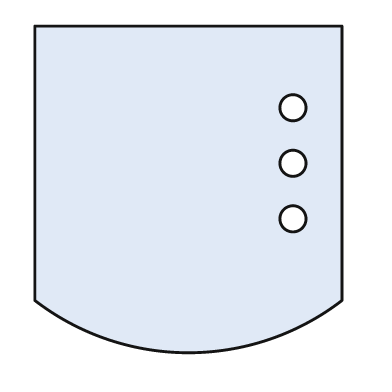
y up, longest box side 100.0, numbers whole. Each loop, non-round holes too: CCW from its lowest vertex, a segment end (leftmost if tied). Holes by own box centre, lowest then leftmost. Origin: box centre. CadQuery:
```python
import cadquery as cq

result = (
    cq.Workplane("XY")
    .moveTo(-47.0, -34.0)
    .threePointArc((0.0, -50.0), (47.0, -34.0))
    .lineTo(47.0, 50.0)
    .lineTo(-47.0, 50.0)
    .close()
    .moveTo(32.0, -9.0)
    .circle(4.0)
    .moveTo(32.0, 8.0)
    .circle(4.0)
    .moveTo(32.0, 25.0)
    .circle(4.0)
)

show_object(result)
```